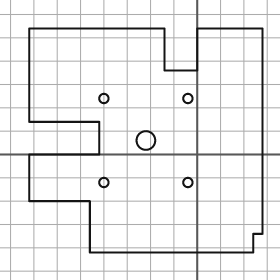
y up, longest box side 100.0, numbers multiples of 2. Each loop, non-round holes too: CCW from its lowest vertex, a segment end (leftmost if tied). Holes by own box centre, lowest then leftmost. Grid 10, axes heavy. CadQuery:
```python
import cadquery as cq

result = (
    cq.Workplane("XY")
    .moveTo(-46.0, -42.0)
    .lineTo(24.0, -42.0)
    .lineTo(24.0, -34.0)
    .lineTo(28.0, -34.0)
    .lineTo(28.0, 54.0)
    .lineTo(0.0, 54.0)
    .lineTo(0.0, 36.0)
    .lineTo(-14.0, 36.0)
    .lineTo(-14.0, 54.0)
    .lineTo(-72.0, 54.0)
    .lineTo(-72.0, 14.0)
    .lineTo(-42.0, 14.0)
    .lineTo(-42.0, 0.0)
    .lineTo(-72.0, 0.0)
    .lineTo(-72.0, -20.0)
    .lineTo(-46.0, -20.0)
    .close()
    .moveTo(-40.0, -12.0)
    .circle(2.0)
    .moveTo(-4.0, -12.0)
    .circle(2.0)
    .moveTo(-22.0, 6.0)
    .circle(4.0)
    .moveTo(-40.0, 24.0)
    .circle(2.0)
    .moveTo(-4.0, 24.0)
    .circle(2.0)
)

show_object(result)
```